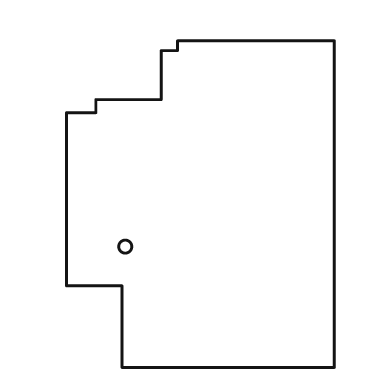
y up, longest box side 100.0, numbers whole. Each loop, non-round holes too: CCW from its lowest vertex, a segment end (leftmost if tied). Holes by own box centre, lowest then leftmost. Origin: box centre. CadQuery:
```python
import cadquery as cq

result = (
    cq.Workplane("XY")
    .moveTo(-24.0, -50.0)
    .lineTo(41.0, -50.0)
    .lineTo(41.0, 50.0)
    .lineTo(-7.0, 50.0)
    .lineTo(-7.0, 47.0)
    .lineTo(-12.0, 47.0)
    .lineTo(-12.0, 32.0)
    .lineTo(-32.0, 32.0)
    .lineTo(-32.0, 28.0)
    .lineTo(-41.0, 28.0)
    .lineTo(-41.0, -25.0)
    .lineTo(-24.0, -25.0)
    .close()
    .moveTo(-23.0, -13.0)
    .circle(2.0)
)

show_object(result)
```